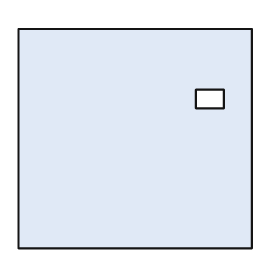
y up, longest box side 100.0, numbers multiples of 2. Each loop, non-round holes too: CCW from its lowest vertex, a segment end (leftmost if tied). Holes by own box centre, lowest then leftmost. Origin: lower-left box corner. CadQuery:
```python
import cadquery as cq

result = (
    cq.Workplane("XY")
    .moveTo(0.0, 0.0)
    .lineTo(100.0, 0.0)
    .lineTo(100.0, 94.0)
    .lineTo(0.0, 94.0)
    .close()
    .moveTo(76.0, 60.0)
    .lineTo(88.0, 60.0)
    .lineTo(88.0, 68.0)
    .lineTo(76.0, 68.0)
    .close()
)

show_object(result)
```